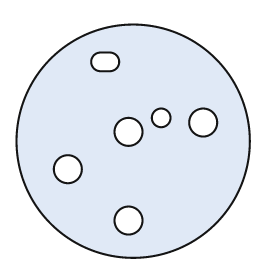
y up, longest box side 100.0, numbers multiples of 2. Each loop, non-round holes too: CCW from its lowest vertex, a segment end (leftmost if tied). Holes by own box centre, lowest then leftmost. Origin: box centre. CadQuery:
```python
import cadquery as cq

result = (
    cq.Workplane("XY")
    .moveTo(0.0, 0.0)
    .circle(50.0)
    .moveTo(-2.0, -34.0)
    .circle(6.0)
    .moveTo(-28.0, -12.0)
    .circle(6.0)
    .moveTo(-2.0, 4.0)
    .circle(6.0)
    .moveTo(30.0, 8.0)
    .circle(6.0)
    .moveTo(12.0, 10.0)
    .circle(4.0)
    .moveTo(-14.0, 30.0)
    .lineTo(-10.0, 30.0)
    .threePointArc((-6.0, 34.0), (-10.0, 38.0))
    .lineTo(-14.0, 38.0)
    .threePointArc((-18.0, 34.0), (-14.0, 30.0))
    .close()
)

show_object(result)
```